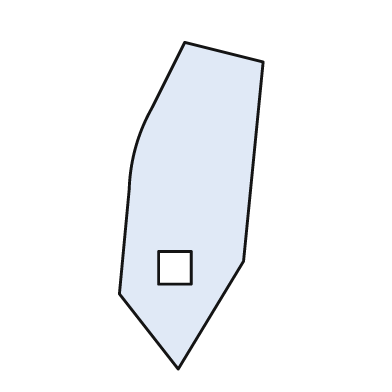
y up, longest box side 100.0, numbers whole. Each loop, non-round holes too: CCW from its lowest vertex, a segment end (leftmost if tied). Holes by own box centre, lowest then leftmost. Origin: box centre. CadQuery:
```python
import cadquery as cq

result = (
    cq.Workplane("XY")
    .moveTo(-4.0, -50.0)
    .lineTo(16.0, -17.0)
    .lineTo(22.0, 44.0)
    .lineTo(-2.0, 50.0)
    .lineTo(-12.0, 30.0)
    .threePointArc((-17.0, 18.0), (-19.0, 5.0))
    .lineTo(-22.0, -27.0)
    .close()
    .moveTo(-10.0, -24.0)
    .lineTo(0.0, -24.0)
    .lineTo(0.0, -14.0)
    .lineTo(-10.0, -14.0)
    .close()
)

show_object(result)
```